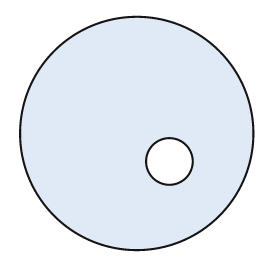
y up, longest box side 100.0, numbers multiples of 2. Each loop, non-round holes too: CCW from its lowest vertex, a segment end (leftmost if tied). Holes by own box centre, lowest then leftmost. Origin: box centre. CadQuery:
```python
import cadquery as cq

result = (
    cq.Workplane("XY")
    .moveTo(0.0, 0.0)
    .circle(50.0)
    .moveTo(14.0, -12.0)
    .circle(10.0)
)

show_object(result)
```